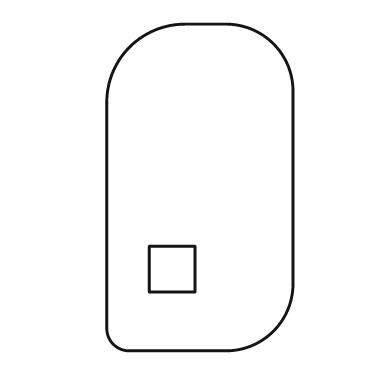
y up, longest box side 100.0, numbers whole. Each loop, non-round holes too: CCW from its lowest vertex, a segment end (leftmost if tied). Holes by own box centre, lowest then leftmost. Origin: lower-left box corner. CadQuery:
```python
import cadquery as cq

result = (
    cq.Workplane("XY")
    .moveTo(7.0, 0.0)
    .lineTo(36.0, 0.0)
    .threePointArc((51.0, 6.0), (57.0, 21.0))
    .lineTo(57.0, 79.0)
    .threePointArc((51.0, 94.0), (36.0, 100.0))
    .lineTo(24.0, 100.0)
    .threePointArc((7.0, 93.0), (0.0, 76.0))
    .lineTo(0.0, 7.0)
    .threePointArc((2.0, 2.0), (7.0, 0.0))
    .close()
    .moveTo(13.0, 18.0)
    .lineTo(27.0, 18.0)
    .lineTo(27.0, 32.0)
    .lineTo(13.0, 32.0)
    .close()
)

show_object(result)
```